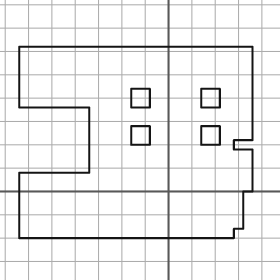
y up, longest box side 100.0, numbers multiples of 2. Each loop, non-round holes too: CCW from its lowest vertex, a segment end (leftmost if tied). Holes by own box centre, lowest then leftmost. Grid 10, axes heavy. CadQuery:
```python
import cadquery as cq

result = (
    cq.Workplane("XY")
    .moveTo(-64.0, -20.0)
    .lineTo(28.0, -20.0)
    .lineTo(28.0, -16.0)
    .lineTo(32.0, -16.0)
    .lineTo(32.0, 0.0)
    .lineTo(36.0, 0.0)
    .lineTo(36.0, 18.0)
    .lineTo(28.0, 18.0)
    .lineTo(28.0, 22.0)
    .lineTo(36.0, 22.0)
    .lineTo(36.0, 62.0)
    .lineTo(-64.0, 62.0)
    .lineTo(-64.0, 36.0)
    .lineTo(-34.0, 36.0)
    .lineTo(-34.0, 8.0)
    .lineTo(-64.0, 8.0)
    .close()
    .moveTo(-16.0, 20.0)
    .lineTo(-8.0, 20.0)
    .lineTo(-8.0, 28.0)
    .lineTo(-16.0, 28.0)
    .close()
    .moveTo(14.0, 20.0)
    .lineTo(22.0, 20.0)
    .lineTo(22.0, 28.0)
    .lineTo(14.0, 28.0)
    .close()
    .moveTo(-16.0, 36.0)
    .lineTo(-8.0, 36.0)
    .lineTo(-8.0, 44.0)
    .lineTo(-16.0, 44.0)
    .close()
    .moveTo(14.0, 36.0)
    .lineTo(22.0, 36.0)
    .lineTo(22.0, 44.0)
    .lineTo(14.0, 44.0)
    .close()
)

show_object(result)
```